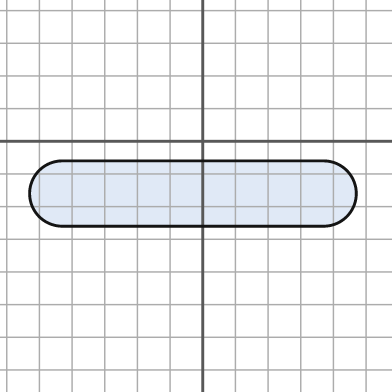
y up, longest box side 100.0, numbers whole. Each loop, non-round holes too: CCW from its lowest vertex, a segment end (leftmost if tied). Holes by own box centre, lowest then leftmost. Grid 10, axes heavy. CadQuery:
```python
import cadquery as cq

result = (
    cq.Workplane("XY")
    .moveTo(-43.0, -26.0)
    .lineTo(37.0, -26.0)
    .threePointArc((47.0, -16.0), (37.0, -6.0))
    .lineTo(-43.0, -6.0)
    .threePointArc((-53.0, -16.0), (-43.0, -26.0))
    .close()
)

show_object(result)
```